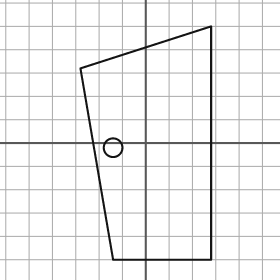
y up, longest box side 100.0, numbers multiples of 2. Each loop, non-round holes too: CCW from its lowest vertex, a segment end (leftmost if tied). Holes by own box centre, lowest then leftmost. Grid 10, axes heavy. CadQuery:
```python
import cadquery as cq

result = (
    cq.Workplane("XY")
    .moveTo(-14.0, -50.0)
    .lineTo(28.0, -50.0)
    .lineTo(28.0, 50.0)
    .lineTo(-28.0, 32.0)
    .close()
    .moveTo(-14.0, -2.0)
    .circle(4.0)
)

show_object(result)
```